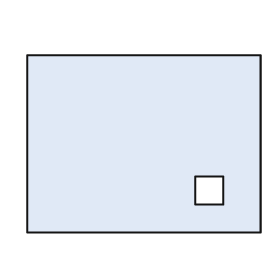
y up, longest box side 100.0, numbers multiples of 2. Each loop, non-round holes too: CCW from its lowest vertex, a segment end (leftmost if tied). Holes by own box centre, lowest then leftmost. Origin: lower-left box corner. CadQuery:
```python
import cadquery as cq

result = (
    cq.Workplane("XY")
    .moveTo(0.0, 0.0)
    .lineTo(100.0, 0.0)
    .lineTo(100.0, 76.0)
    .lineTo(0.0, 76.0)
    .close()
    .moveTo(72.0, 12.0)
    .lineTo(84.0, 12.0)
    .lineTo(84.0, 24.0)
    .lineTo(72.0, 24.0)
    .close()
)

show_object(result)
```